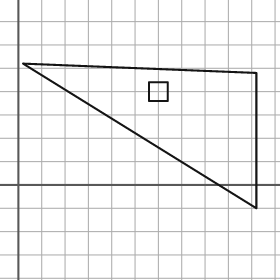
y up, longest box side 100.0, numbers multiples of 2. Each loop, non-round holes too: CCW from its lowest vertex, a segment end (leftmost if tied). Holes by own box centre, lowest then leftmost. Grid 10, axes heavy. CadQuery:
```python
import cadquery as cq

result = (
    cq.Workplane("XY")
    .moveTo(102.0, -10.0)
    .lineTo(102.0, 48.0)
    .lineTo(2.0, 52.0)
    .close()
    .moveTo(56.0, 36.0)
    .lineTo(64.0, 36.0)
    .lineTo(64.0, 44.0)
    .lineTo(56.0, 44.0)
    .close()
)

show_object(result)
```